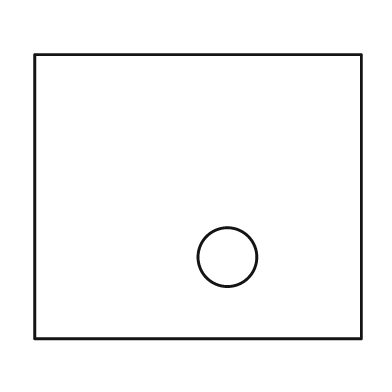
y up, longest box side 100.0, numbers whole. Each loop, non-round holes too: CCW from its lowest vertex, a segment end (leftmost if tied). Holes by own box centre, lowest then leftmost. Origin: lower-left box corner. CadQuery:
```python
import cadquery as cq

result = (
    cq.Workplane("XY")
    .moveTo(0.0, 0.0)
    .lineTo(100.0, 0.0)
    .lineTo(100.0, 87.0)
    .lineTo(0.0, 87.0)
    .close()
    .moveTo(59.0, 25.0)
    .circle(9.0)
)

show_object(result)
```